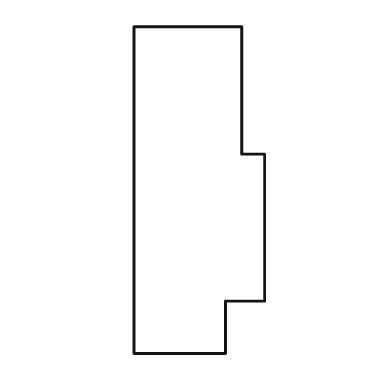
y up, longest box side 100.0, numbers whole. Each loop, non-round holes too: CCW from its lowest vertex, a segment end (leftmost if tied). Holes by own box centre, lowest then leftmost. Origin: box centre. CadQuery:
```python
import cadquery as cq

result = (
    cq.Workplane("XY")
    .moveTo(-20.0, -50.0)
    .lineTo(8.0, -50.0)
    .lineTo(8.0, -34.0)
    .lineTo(20.0, -34.0)
    .lineTo(20.0, 11.0)
    .lineTo(13.0, 11.0)
    .lineTo(13.0, 50.0)
    .lineTo(-20.0, 50.0)
    .close()
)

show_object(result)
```